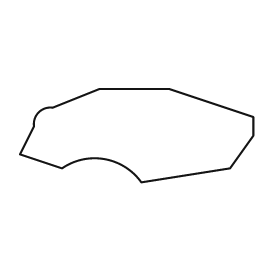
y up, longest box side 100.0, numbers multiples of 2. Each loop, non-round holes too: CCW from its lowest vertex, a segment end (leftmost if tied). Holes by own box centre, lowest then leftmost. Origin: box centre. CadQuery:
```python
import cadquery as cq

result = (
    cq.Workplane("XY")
    .moveTo(2.0, -20.0)
    .lineTo(40.0, -14.0)
    .lineTo(50.0, 0.0)
    .lineTo(50.0, 8.0)
    .lineTo(14.0, 20.0)
    .lineTo(-16.0, 20.0)
    .lineTo(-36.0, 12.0)
    .threePointArc((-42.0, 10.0), (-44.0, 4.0))
    .lineTo(-50.0, -8.0)
    .lineTo(-32.0, -14.0)
    .threePointArc((-14.0, -10.0), (2.0, -20.0))
    .close()
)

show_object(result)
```